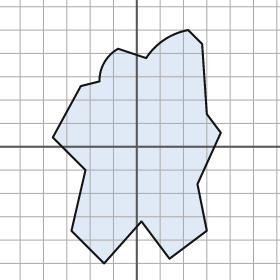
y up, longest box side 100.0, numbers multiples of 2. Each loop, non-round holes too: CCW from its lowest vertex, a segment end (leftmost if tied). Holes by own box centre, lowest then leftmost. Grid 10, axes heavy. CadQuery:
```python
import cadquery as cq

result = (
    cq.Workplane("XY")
    .moveTo(-14.0, -50.0)
    .lineTo(2.0, -32.0)
    .lineTo(14.0, -48.0)
    .lineTo(30.0, -36.0)
    .lineTo(26.0, -16.0)
    .lineTo(36.0, 6.0)
    .lineTo(30.0, 14.0)
    .lineTo(28.0, 44.0)
    .lineTo(22.0, 50.0)
    .threePointArc((12.0, 46.0), (4.0, 38.0))
    .lineTo(-8.0, 42.0)
    .threePointArc((-14.0, 36.0), (-16.0, 28.0))
    .lineTo(-24.0, 26.0)
    .lineTo(-36.0, 4.0)
    .lineTo(-22.0, -10.0)
    .lineTo(-28.0, -36.0)
    .close()
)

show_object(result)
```